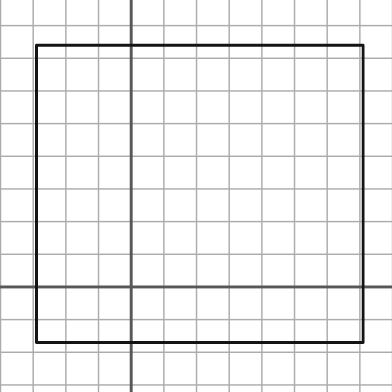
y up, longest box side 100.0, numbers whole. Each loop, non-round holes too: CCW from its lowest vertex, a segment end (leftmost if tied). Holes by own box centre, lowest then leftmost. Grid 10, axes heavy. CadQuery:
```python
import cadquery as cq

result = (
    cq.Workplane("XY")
    .moveTo(-29.0, -17.0)
    .lineTo(71.0, -17.0)
    .lineTo(71.0, 74.0)
    .lineTo(-29.0, 74.0)
    .close()
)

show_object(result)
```